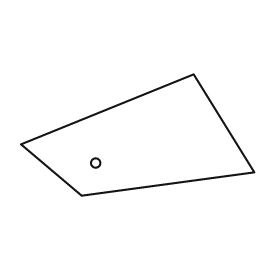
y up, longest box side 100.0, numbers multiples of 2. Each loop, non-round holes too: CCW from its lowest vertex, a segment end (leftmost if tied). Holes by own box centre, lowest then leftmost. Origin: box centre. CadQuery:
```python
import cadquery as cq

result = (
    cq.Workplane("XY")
    .moveTo(-24.0, -26.0)
    .lineTo(50.0, -16.0)
    .lineTo(24.0, 26.0)
    .lineTo(-50.0, -4.0)
    .close()
    .moveTo(-18.0, -12.0)
    .circle(2.0)
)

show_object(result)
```